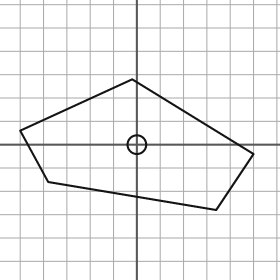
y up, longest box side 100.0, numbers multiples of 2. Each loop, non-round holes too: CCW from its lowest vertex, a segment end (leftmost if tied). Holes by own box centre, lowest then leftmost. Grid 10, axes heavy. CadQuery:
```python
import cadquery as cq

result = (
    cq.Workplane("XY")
    .moveTo(34.0, -28.0)
    .lineTo(50.0, -4.0)
    .lineTo(-2.0, 28.0)
    .lineTo(-50.0, 6.0)
    .lineTo(-38.0, -16.0)
    .close()
    .moveTo(0.0, 0.0)
    .circle(4.0)
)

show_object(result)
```